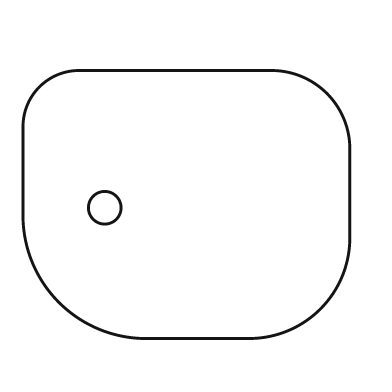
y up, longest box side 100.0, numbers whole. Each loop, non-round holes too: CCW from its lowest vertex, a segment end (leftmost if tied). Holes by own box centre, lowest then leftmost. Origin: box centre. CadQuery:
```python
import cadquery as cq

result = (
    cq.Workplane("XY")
    .moveTo(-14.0, -41.0)
    .lineTo(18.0, -41.0)
    .threePointArc((41.0, -32.0), (50.0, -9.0))
    .lineTo(50.0, 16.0)
    .threePointArc((43.0, 34.0), (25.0, 41.0))
    .lineTo(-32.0, 41.0)
    .threePointArc((-45.0, 36.0), (-50.0, 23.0))
    .lineTo(-50.0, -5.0)
    .threePointArc((-39.0, -30.0), (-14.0, -41.0))
    .close()
    .moveTo(-25.0, -1.0)
    .circle(5.0)
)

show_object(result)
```